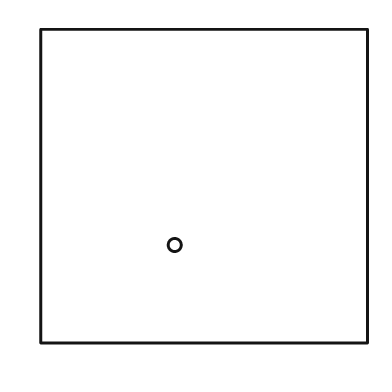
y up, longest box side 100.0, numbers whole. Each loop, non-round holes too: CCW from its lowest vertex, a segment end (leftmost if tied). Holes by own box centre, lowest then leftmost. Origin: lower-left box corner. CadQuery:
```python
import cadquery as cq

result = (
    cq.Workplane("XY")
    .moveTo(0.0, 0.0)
    .lineTo(100.0, 0.0)
    .lineTo(100.0, 96.0)
    .lineTo(0.0, 96.0)
    .close()
    .moveTo(41.0, 30.0)
    .circle(2.0)
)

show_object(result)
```